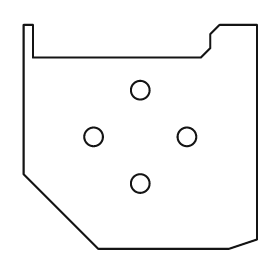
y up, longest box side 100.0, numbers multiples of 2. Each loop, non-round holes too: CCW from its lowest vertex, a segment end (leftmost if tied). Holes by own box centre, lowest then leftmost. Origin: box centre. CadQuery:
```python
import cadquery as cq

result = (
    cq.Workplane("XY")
    .moveTo(-18.0, -48.0)
    .lineTo(38.0, -48.0)
    .lineTo(50.0, -44.0)
    .lineTo(50.0, 48.0)
    .lineTo(34.0, 48.0)
    .lineTo(30.0, 44.0)
    .lineTo(30.0, 38.0)
    .lineTo(26.0, 34.0)
    .lineTo(-46.0, 34.0)
    .lineTo(-46.0, 48.0)
    .lineTo(-50.0, 48.0)
    .lineTo(-50.0, -16.0)
    .close()
    .moveTo(0.0, -20.0)
    .circle(4.0)
    .moveTo(-20.0, 0.0)
    .circle(4.0)
    .moveTo(20.0, 0.0)
    .circle(4.0)
    .moveTo(0.0, 20.0)
    .circle(4.0)
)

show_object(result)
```